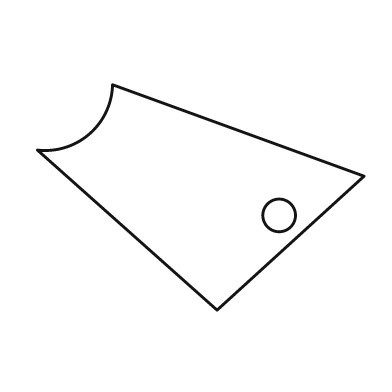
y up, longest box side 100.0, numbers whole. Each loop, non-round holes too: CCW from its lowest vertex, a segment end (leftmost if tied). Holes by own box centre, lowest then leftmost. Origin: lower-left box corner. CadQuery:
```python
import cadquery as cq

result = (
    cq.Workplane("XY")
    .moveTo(55.0, 0.0)
    .lineTo(100.0, 41.0)
    .lineTo(23.0, 69.0)
    .threePointArc((16.0, 54.0), (0.0, 49.0))
    .close()
    .moveTo(74.0, 29.0)
    .circle(5.0)
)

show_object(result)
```